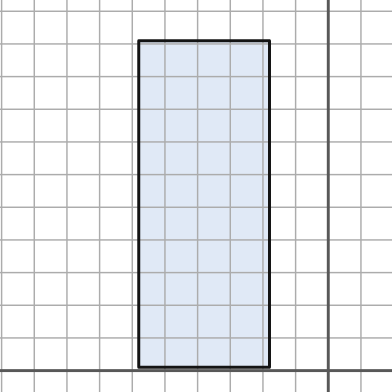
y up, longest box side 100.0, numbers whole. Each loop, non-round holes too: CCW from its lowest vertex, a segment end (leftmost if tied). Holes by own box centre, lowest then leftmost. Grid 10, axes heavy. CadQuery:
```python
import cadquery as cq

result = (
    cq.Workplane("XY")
    .moveTo(-58.0, 1.0)
    .lineTo(-18.0, 1.0)
    .lineTo(-18.0, 101.0)
    .lineTo(-58.0, 101.0)
    .close()
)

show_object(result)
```